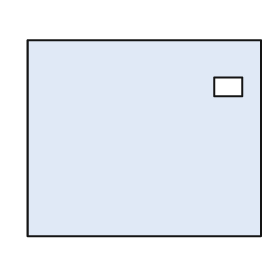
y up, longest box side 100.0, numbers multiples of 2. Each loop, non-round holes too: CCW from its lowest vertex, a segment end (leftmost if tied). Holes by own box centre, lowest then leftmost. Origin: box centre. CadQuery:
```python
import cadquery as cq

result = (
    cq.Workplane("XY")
    .moveTo(-50.0, -42.0)
    .lineTo(50.0, -42.0)
    .lineTo(50.0, 42.0)
    .lineTo(-50.0, 42.0)
    .close()
    .moveTo(30.0, 18.0)
    .lineTo(42.0, 18.0)
    .lineTo(42.0, 26.0)
    .lineTo(30.0, 26.0)
    .close()
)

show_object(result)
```